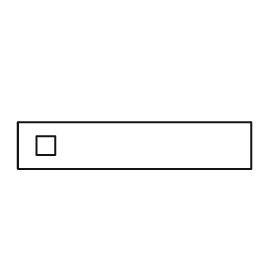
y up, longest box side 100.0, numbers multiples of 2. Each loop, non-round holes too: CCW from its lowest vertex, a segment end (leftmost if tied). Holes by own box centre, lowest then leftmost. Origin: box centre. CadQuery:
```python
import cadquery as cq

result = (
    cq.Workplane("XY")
    .moveTo(-50.0, -10.0)
    .lineTo(50.0, -10.0)
    .lineTo(50.0, 10.0)
    .lineTo(-50.0, 10.0)
    .close()
    .moveTo(-42.0, -4.0)
    .lineTo(-34.0, -4.0)
    .lineTo(-34.0, 4.0)
    .lineTo(-42.0, 4.0)
    .close()
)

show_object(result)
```